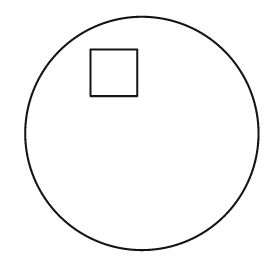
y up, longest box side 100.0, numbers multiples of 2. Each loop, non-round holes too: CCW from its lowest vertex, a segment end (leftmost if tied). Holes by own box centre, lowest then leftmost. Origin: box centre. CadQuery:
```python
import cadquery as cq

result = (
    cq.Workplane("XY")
    .moveTo(0.0, 0.0)
    .circle(50.0)
    .moveTo(-22.0, 16.0)
    .lineTo(-2.0, 16.0)
    .lineTo(-2.0, 36.0)
    .lineTo(-22.0, 36.0)
    .close()
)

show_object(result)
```